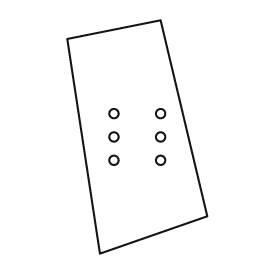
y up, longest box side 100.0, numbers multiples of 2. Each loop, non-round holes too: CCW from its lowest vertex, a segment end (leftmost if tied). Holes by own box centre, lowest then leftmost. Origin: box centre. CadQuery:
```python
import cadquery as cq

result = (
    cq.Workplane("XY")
    .moveTo(-16.0, -50.0)
    .lineTo(30.0, -34.0)
    .lineTo(10.0, 50.0)
    .lineTo(-30.0, 42.0)
    .close()
    .moveTo(-10.0, -10.0)
    .circle(2.0)
    .moveTo(10.0, -10.0)
    .circle(2.0)
    .moveTo(-10.0, 0.0)
    .circle(2.0)
    .moveTo(10.0, 0.0)
    .circle(2.0)
    .moveTo(-10.0, 10.0)
    .circle(2.0)
    .moveTo(10.0, 10.0)
    .circle(2.0)
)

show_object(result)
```